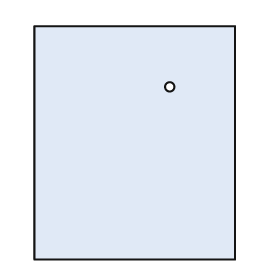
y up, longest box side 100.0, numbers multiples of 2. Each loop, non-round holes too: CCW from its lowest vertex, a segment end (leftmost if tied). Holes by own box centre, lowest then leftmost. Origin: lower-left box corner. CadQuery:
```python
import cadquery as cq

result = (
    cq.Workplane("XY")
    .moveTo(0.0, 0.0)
    .lineTo(86.0, 0.0)
    .lineTo(86.0, 100.0)
    .lineTo(0.0, 100.0)
    .close()
    .moveTo(58.0, 74.0)
    .circle(2.0)
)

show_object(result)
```